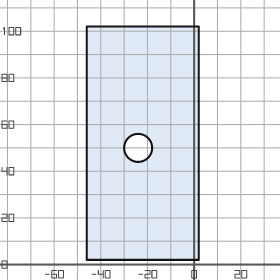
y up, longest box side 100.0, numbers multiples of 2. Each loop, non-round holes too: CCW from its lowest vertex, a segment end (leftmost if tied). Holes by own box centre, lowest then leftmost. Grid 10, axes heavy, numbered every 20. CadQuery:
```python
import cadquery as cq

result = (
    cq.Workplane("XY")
    .moveTo(-46.0, 2.0)
    .lineTo(2.0, 2.0)
    .lineTo(2.0, 102.0)
    .lineTo(-46.0, 102.0)
    .close()
    .moveTo(-24.0, 50.0)
    .circle(6.0)
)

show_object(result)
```